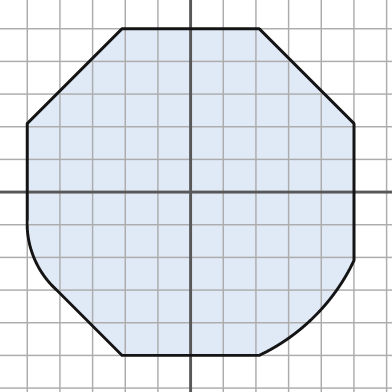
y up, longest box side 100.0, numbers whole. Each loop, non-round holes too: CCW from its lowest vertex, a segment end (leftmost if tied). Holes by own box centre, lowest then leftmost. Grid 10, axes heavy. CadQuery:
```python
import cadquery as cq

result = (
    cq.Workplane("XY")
    .moveTo(-21.0, -50.0)
    .lineTo(21.0, -50.0)
    .threePointArc((38.0, -38.0), (50.0, -21.0))
    .lineTo(50.0, 21.0)
    .lineTo(21.0, 50.0)
    .lineTo(-21.0, 50.0)
    .lineTo(-50.0, 21.0)
    .lineTo(-50.0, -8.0)
    .threePointArc((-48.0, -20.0), (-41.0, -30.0))
    .close()
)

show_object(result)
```